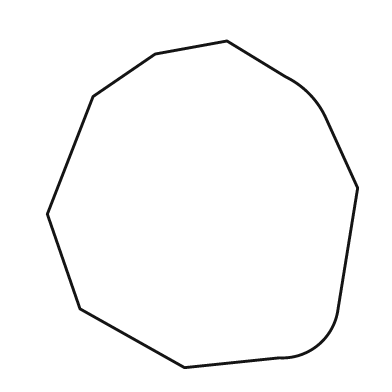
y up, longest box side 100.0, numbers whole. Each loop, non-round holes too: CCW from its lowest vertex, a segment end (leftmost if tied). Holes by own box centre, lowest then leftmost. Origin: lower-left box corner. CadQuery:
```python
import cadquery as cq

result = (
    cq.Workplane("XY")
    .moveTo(42.0, 0.0)
    .lineTo(71.0, 3.0)
    .threePointArc((83.0, 7.0), (89.0, 18.0))
    .lineTo(95.0, 55.0)
    .lineTo(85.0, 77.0)
    .threePointArc((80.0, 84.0), (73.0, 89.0))
    .lineTo(55.0, 100.0)
    .lineTo(33.0, 96.0)
    .lineTo(14.0, 83.0)
    .lineTo(0.0, 47.0)
    .lineTo(10.0, 18.0)
    .close()
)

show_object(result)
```